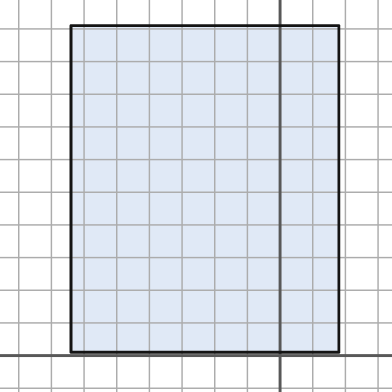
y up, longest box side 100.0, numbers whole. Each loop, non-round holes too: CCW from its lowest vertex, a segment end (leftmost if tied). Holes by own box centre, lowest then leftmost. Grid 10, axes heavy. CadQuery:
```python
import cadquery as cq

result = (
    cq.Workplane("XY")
    .moveTo(-64.0, 1.0)
    .lineTo(18.0, 1.0)
    .lineTo(18.0, 101.0)
    .lineTo(-64.0, 101.0)
    .close()
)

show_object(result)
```